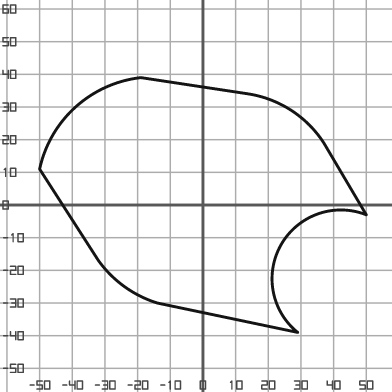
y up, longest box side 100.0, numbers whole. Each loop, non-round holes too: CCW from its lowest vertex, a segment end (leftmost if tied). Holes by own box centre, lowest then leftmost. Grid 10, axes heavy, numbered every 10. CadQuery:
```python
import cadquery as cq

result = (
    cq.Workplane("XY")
    .moveTo(29.0, -39.0)
    .threePointArc((24.0, -12.0), (50.0, -3.0))
    .lineTo(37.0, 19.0)
    .threePointArc((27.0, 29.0), (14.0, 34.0))
    .lineTo(-19.0, 39.0)
    .threePointArc((-39.0, 30.0), (-50.0, 11.0))
    .lineTo(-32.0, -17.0)
    .threePointArc((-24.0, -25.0), (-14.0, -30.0))
    .close()
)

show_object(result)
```